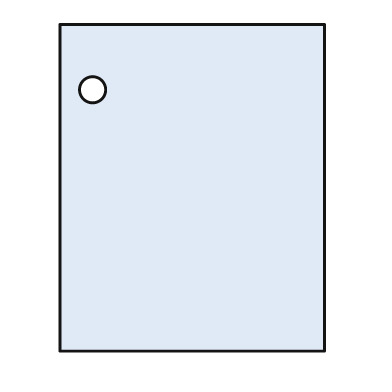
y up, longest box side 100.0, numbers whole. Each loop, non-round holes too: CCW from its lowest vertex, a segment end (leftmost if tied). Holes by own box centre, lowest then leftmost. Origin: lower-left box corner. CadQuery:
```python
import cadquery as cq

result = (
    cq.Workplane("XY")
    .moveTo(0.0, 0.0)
    .lineTo(81.0, 0.0)
    .lineTo(81.0, 100.0)
    .lineTo(0.0, 100.0)
    .close()
    .moveTo(10.0, 80.0)
    .circle(4.0)
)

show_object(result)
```